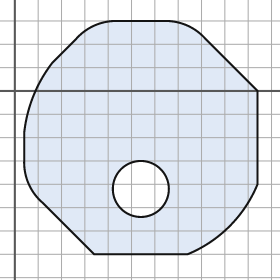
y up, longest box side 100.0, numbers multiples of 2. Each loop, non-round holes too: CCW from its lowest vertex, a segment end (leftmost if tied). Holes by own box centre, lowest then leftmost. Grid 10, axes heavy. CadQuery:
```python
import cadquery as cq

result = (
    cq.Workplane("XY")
    .moveTo(34.0, -70.0)
    .lineTo(74.0, -70.0)
    .threePointArc((92.0, -58.0), (104.0, -40.0))
    .lineTo(104.0, 0.0)
    .lineTo(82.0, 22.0)
    .threePointArc((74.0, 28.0), (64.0, 30.0))
    .lineTo(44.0, 30.0)
    .threePointArc((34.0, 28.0), (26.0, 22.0))
    .lineTo(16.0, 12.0)
    .threePointArc((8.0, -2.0), (4.0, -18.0))
    .lineTo(4.0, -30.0)
    .threePointArc((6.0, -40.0), (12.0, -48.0))
    .close()
    .moveTo(54.0, -42.0)
    .circle(12.0)
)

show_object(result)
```